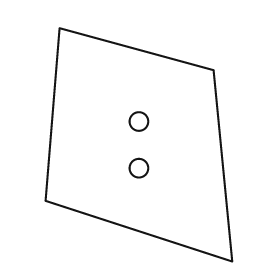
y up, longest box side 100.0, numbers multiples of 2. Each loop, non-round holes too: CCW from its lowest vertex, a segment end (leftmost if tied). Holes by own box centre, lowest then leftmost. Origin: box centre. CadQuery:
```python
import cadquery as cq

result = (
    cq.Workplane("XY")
    .moveTo(40.0, -50.0)
    .lineTo(32.0, 32.0)
    .lineTo(-34.0, 50.0)
    .lineTo(-40.0, -24.0)
    .close()
    .moveTo(0.0, -10.0)
    .circle(4.0)
    .moveTo(0.0, 10.0)
    .circle(4.0)
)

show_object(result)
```